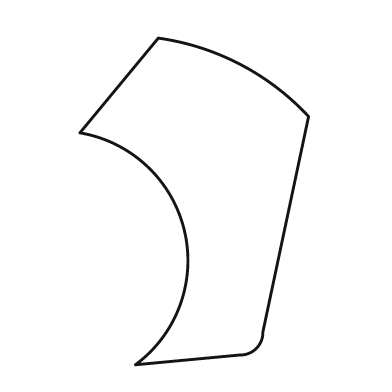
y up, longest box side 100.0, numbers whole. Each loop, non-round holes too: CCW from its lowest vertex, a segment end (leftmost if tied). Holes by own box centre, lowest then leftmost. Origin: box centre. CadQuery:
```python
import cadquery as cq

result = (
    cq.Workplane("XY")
    .moveTo(-18.0, -50.0)
    .lineTo(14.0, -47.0)
    .threePointArc((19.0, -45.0), (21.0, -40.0))
    .lineTo(35.0, 26.0)
    .threePointArc((14.0, 42.0), (-11.0, 50.0))
    .lineTo(-35.0, 21.0)
    .threePointArc((-3.0, -9.0), (-18.0, -50.0))
    .close()
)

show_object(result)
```